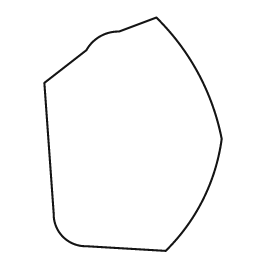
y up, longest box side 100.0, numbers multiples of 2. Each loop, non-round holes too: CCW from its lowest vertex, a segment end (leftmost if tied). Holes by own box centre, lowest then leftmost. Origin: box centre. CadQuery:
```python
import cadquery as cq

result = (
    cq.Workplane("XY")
    .moveTo(14.0, -50.0)
    .threePointArc((30.0, -28.0), (38.0, -2.0))
    .threePointArc((28.0, 26.0), (10.0, 50.0))
    .lineTo(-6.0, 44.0)
    .threePointArc((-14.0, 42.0), (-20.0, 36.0))
    .lineTo(-38.0, 22.0)
    .lineTo(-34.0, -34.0)
    .threePointArc((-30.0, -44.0), (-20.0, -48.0))
    .close()
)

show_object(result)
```